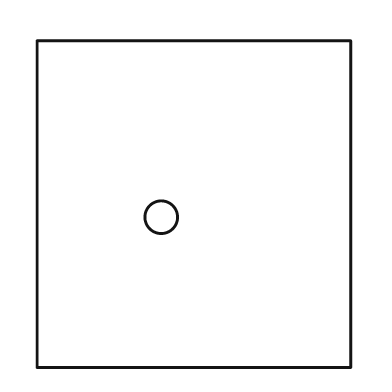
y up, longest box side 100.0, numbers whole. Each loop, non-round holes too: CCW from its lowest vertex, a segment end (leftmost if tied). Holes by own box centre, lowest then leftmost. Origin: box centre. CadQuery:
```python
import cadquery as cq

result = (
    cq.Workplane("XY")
    .moveTo(-48.0, -50.0)
    .lineTo(48.0, -50.0)
    .lineTo(48.0, 50.0)
    .lineTo(-48.0, 50.0)
    .close()
    .moveTo(-10.0, -4.0)
    .circle(5.0)
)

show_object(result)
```